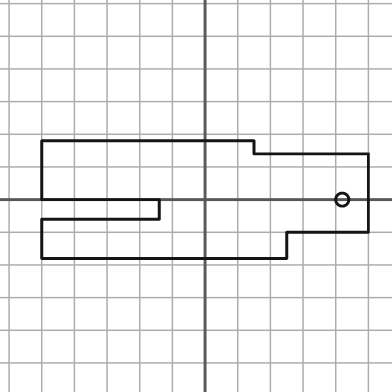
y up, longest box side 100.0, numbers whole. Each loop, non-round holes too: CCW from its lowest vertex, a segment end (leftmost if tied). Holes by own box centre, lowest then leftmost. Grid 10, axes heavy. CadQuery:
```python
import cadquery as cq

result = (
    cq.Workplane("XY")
    .moveTo(-50.0, -18.0)
    .lineTo(25.0, -18.0)
    .lineTo(25.0, -10.0)
    .lineTo(50.0, -10.0)
    .lineTo(50.0, 14.0)
    .lineTo(15.0, 14.0)
    .lineTo(15.0, 18.0)
    .lineTo(-50.0, 18.0)
    .lineTo(-50.0, 0.0)
    .lineTo(-14.0, 0.0)
    .lineTo(-14.0, -6.0)
    .lineTo(-50.0, -6.0)
    .close()
    .moveTo(42.0, 0.0)
    .circle(2.0)
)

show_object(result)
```